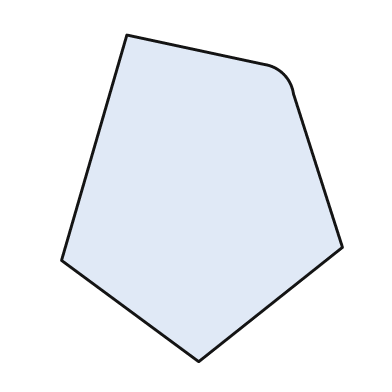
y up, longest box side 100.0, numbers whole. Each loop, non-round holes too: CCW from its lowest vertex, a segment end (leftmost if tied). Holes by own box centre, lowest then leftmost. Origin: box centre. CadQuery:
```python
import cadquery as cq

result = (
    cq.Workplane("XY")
    .moveTo(-1.0, -50.0)
    .lineTo(43.0, -15.0)
    .lineTo(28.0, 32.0)
    .threePointArc((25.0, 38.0), (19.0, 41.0))
    .lineTo(-23.0, 50.0)
    .lineTo(-43.0, -19.0)
    .close()
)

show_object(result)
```